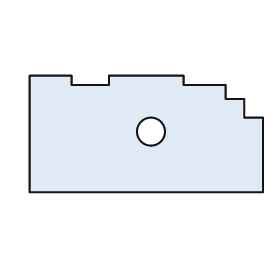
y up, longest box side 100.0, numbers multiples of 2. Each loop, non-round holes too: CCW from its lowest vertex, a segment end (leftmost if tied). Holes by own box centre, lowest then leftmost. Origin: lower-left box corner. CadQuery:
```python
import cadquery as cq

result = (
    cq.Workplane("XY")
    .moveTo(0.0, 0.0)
    .lineTo(100.0, 0.0)
    .lineTo(100.0, 32.0)
    .lineTo(92.0, 32.0)
    .lineTo(92.0, 40.0)
    .lineTo(84.0, 40.0)
    .lineTo(84.0, 46.0)
    .lineTo(66.0, 46.0)
    .lineTo(66.0, 50.0)
    .lineTo(34.0, 50.0)
    .lineTo(34.0, 46.0)
    .lineTo(18.0, 46.0)
    .lineTo(18.0, 50.0)
    .lineTo(0.0, 50.0)
    .close()
    .moveTo(52.0, 26.0)
    .circle(6.0)
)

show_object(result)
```